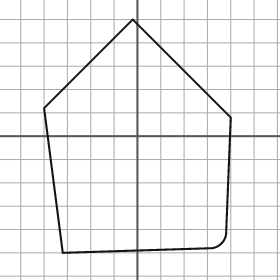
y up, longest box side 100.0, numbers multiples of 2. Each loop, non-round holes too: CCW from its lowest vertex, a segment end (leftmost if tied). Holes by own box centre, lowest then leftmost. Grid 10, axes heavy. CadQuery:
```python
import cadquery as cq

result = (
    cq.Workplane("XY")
    .moveTo(-32.0, -50.0)
    .lineTo(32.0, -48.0)
    .threePointArc((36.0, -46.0), (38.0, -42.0))
    .lineTo(40.0, 8.0)
    .lineTo(-2.0, 50.0)
    .lineTo(-40.0, 12.0)
    .close()
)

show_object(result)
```